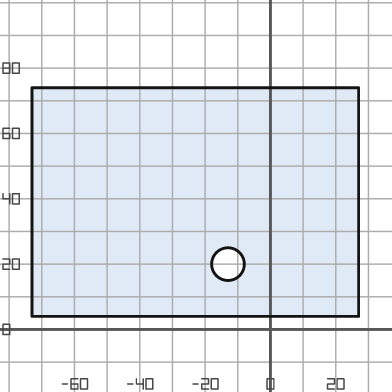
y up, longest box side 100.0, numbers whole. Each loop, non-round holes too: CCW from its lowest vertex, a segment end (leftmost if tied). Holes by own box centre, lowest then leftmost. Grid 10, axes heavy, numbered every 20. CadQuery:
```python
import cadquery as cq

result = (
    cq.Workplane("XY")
    .moveTo(-73.0, 4.0)
    .lineTo(27.0, 4.0)
    .lineTo(27.0, 74.0)
    .lineTo(-73.0, 74.0)
    .close()
    .moveTo(-13.0, 20.0)
    .circle(5.0)
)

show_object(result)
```